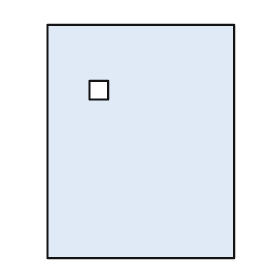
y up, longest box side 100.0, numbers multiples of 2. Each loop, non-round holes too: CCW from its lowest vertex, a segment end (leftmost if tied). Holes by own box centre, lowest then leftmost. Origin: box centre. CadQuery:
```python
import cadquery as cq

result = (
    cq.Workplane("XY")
    .moveTo(-40.0, -50.0)
    .lineTo(40.0, -50.0)
    .lineTo(40.0, 50.0)
    .lineTo(-40.0, 50.0)
    .close()
    .moveTo(-22.0, 18.0)
    .lineTo(-14.0, 18.0)
    .lineTo(-14.0, 26.0)
    .lineTo(-22.0, 26.0)
    .close()
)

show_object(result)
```